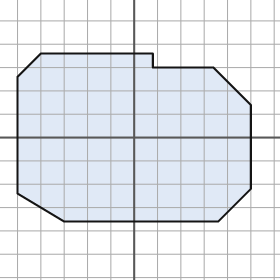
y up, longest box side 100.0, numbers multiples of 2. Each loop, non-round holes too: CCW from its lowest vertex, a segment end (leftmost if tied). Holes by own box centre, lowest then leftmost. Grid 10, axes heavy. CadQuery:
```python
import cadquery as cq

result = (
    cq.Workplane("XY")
    .moveTo(-30.0, -36.0)
    .lineTo(36.0, -36.0)
    .lineTo(50.0, -22.0)
    .lineTo(50.0, 14.0)
    .lineTo(34.0, 30.0)
    .lineTo(8.0, 30.0)
    .lineTo(8.0, 36.0)
    .lineTo(-40.0, 36.0)
    .lineTo(-50.0, 26.0)
    .lineTo(-50.0, -24.0)
    .close()
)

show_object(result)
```